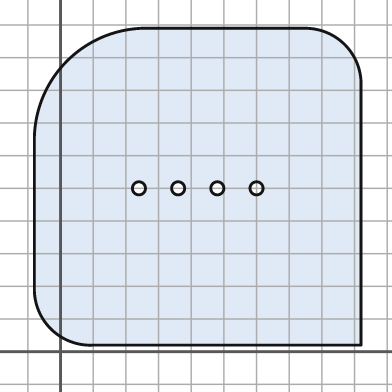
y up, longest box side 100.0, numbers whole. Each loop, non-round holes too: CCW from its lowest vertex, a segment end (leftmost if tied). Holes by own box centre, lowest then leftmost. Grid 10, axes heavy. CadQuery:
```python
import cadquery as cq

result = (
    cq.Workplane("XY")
    .moveTo(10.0, 2.0)
    .lineTo(92.0, 2.0)
    .lineTo(92.0, 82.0)
    .threePointArc((87.0, 94.0), (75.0, 99.0))
    .lineTo(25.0, 99.0)
    .threePointArc((2.0, 89.0), (-8.0, 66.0))
    .lineTo(-8.0, 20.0)
    .threePointArc((-3.0, 7.0), (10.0, 2.0))
    .close()
    .moveTo(24.0, 50.0)
    .circle(2.0)
    .moveTo(36.0, 50.0)
    .circle(2.0)
    .moveTo(48.0, 50.0)
    .circle(2.0)
    .moveTo(60.0, 50.0)
    .circle(2.0)
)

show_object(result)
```